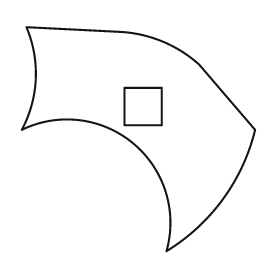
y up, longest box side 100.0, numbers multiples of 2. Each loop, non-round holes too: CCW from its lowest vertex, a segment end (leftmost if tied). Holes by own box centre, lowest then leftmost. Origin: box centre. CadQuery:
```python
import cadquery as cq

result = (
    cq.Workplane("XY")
    .moveTo(12.0, -48.0)
    .threePointArc((36.0, -26.0), (50.0, 4.0))
    .lineTo(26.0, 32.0)
    .threePointArc((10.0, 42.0), (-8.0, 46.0))
    .lineTo(-48.0, 48.0)
    .threePointArc((-44.0, 26.0), (-50.0, 4.0))
    .threePointArc((-2.0, -2.0), (12.0, -48.0))
    .close()
    .moveTo(-6.0, 6.0)
    .lineTo(10.0, 6.0)
    .lineTo(10.0, 22.0)
    .lineTo(-6.0, 22.0)
    .close()
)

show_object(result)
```